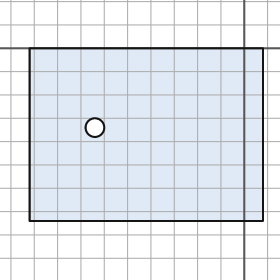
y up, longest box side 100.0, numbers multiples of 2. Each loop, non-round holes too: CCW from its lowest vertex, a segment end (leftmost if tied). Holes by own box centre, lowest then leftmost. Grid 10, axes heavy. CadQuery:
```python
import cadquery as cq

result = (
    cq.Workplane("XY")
    .moveTo(-92.0, -74.0)
    .lineTo(8.0, -74.0)
    .lineTo(8.0, 0.0)
    .lineTo(-92.0, 0.0)
    .close()
    .moveTo(-64.0, -34.0)
    .circle(4.0)
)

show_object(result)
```